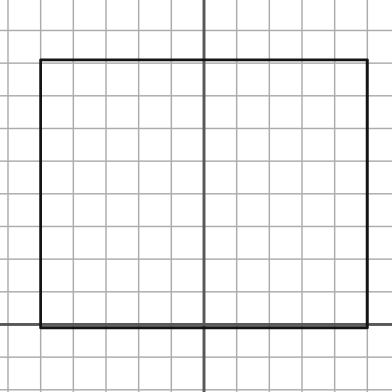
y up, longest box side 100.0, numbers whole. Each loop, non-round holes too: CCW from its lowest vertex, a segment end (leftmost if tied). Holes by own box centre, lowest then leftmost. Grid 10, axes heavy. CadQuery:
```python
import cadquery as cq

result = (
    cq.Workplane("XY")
    .moveTo(-50.0, -1.0)
    .lineTo(50.0, -1.0)
    .lineTo(50.0, 81.0)
    .lineTo(-50.0, 81.0)
    .close()
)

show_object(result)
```